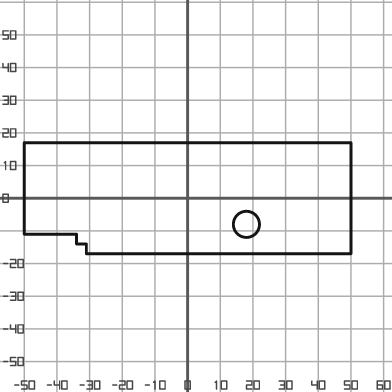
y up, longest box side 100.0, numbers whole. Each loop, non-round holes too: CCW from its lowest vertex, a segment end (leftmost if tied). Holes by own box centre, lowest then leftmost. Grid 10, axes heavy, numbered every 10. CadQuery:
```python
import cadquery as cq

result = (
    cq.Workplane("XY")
    .moveTo(-31.0, -17.0)
    .lineTo(50.0, -17.0)
    .lineTo(50.0, 17.0)
    .lineTo(-50.0, 17.0)
    .lineTo(-50.0, -11.0)
    .lineTo(-34.0, -11.0)
    .lineTo(-34.0, -14.0)
    .lineTo(-31.0, -14.0)
    .close()
    .moveTo(18.0, -8.0)
    .circle(4.0)
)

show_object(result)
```